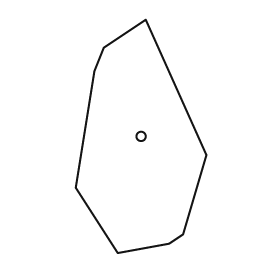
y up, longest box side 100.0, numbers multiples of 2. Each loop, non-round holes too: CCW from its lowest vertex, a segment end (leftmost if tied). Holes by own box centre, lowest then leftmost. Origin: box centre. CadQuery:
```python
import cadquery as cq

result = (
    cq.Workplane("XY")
    .moveTo(-10.0, -50.0)
    .lineTo(12.0, -46.0)
    .lineTo(18.0, -42.0)
    .lineTo(28.0, -8.0)
    .lineTo(2.0, 50.0)
    .lineTo(-16.0, 38.0)
    .lineTo(-20.0, 28.0)
    .lineTo(-28.0, -22.0)
    .close()
    .moveTo(0.0, 0.0)
    .circle(2.0)
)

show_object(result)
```